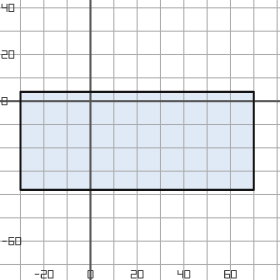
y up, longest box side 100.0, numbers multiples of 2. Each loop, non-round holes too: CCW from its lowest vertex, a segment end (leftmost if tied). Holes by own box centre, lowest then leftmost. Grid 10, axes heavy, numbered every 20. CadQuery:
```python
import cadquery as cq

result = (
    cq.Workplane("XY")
    .moveTo(-30.0, -38.0)
    .lineTo(70.0, -38.0)
    .lineTo(70.0, 4.0)
    .lineTo(-30.0, 4.0)
    .close()
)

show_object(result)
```